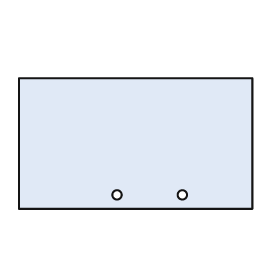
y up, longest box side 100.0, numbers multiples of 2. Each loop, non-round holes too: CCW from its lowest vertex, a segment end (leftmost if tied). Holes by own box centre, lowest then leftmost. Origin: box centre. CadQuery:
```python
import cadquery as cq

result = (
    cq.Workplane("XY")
    .moveTo(-50.0, -28.0)
    .lineTo(50.0, -28.0)
    .lineTo(50.0, 28.0)
    .lineTo(-50.0, 28.0)
    .close()
    .moveTo(-8.0, -22.0)
    .circle(2.0)
    .moveTo(20.0, -22.0)
    .circle(2.0)
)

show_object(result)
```